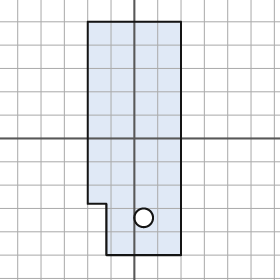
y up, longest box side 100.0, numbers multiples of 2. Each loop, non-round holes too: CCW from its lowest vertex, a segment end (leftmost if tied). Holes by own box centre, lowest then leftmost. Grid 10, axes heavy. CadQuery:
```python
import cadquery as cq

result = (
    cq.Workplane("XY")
    .moveTo(-12.0, -50.0)
    .lineTo(20.0, -50.0)
    .lineTo(20.0, 50.0)
    .lineTo(-20.0, 50.0)
    .lineTo(-20.0, -28.0)
    .lineTo(-12.0, -28.0)
    .close()
    .moveTo(4.0, -34.0)
    .circle(4.0)
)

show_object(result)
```